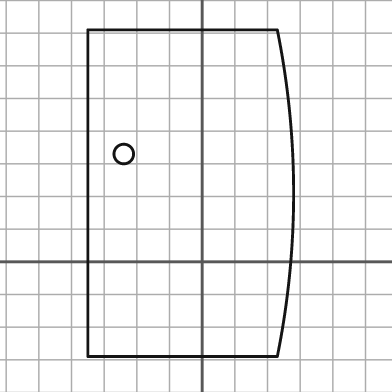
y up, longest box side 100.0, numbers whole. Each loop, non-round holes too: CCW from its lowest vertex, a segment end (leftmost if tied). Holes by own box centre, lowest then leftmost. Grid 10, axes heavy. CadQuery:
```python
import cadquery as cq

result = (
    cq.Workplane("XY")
    .moveTo(-35.0, -29.0)
    .lineTo(23.0, -29.0)
    .threePointArc((28.0, 21.0), (23.0, 71.0))
    .lineTo(-35.0, 71.0)
    .close()
    .moveTo(-24.0, 33.0)
    .circle(3.0)
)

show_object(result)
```